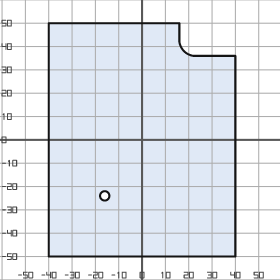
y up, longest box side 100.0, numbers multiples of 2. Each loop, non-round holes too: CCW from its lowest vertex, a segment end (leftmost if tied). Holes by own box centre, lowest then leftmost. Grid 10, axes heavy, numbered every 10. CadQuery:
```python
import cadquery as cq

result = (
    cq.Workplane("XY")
    .moveTo(-40.0, -50.0)
    .lineTo(40.0, -50.0)
    .lineTo(40.0, 36.0)
    .lineTo(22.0, 36.0)
    .threePointArc((18.0, 38.0), (16.0, 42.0))
    .lineTo(16.0, 50.0)
    .lineTo(-40.0, 50.0)
    .close()
    .moveTo(-16.0, -24.0)
    .circle(2.0)
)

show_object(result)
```